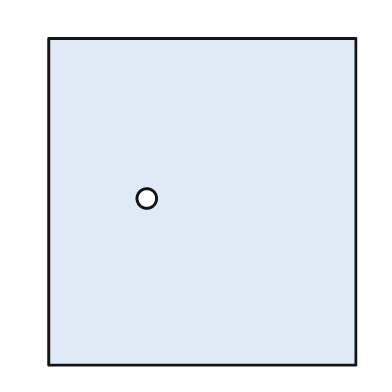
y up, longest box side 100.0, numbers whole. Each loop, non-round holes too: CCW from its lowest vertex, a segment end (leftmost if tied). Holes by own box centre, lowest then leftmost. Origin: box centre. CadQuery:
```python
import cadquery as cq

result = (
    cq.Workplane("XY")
    .moveTo(-47.0, -50.0)
    .lineTo(47.0, -50.0)
    .lineTo(47.0, 50.0)
    .lineTo(-47.0, 50.0)
    .close()
    .moveTo(-17.0, 1.0)
    .circle(3.0)
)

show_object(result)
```